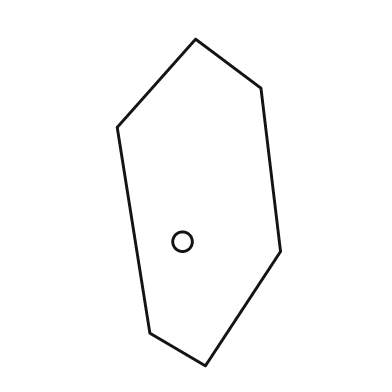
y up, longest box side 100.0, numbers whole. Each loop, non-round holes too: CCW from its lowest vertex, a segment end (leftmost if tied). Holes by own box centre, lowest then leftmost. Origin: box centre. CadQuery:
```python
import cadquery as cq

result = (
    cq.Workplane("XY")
    .moveTo(2.0, -50.0)
    .lineTo(25.0, -15.0)
    .lineTo(19.0, 35.0)
    .lineTo(-1.0, 50.0)
    .lineTo(-25.0, 23.0)
    .lineTo(-15.0, -40.0)
    .close()
    .moveTo(-5.0, -12.0)
    .circle(3.0)
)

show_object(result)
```